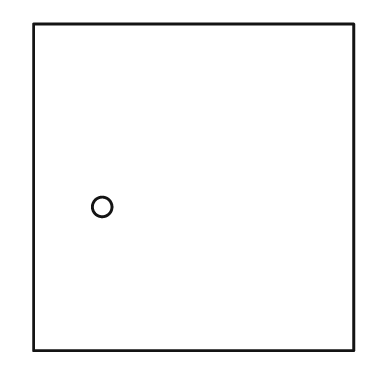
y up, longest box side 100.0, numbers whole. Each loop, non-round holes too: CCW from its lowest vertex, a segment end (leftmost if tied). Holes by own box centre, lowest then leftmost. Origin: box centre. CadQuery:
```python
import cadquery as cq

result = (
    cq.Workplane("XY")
    .moveTo(-49.0, -50.0)
    .lineTo(49.0, -50.0)
    .lineTo(49.0, 50.0)
    .lineTo(-49.0, 50.0)
    .close()
    .moveTo(-28.0, -6.0)
    .circle(3.0)
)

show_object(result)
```